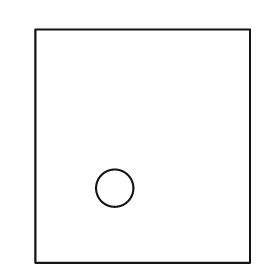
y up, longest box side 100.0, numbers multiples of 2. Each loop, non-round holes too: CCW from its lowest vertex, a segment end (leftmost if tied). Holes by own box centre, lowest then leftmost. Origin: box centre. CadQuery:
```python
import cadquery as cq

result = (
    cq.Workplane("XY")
    .moveTo(-46.0, -50.0)
    .lineTo(46.0, -50.0)
    .lineTo(46.0, 50.0)
    .lineTo(-46.0, 50.0)
    .close()
    .moveTo(-12.0, -18.0)
    .circle(8.0)
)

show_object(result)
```